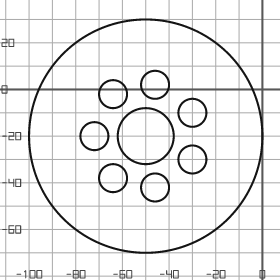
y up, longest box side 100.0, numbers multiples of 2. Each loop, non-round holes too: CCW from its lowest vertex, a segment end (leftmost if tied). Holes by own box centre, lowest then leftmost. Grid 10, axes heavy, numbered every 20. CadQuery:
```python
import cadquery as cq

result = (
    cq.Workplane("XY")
    .moveTo(-50.0, -20.0)
    .circle(50.0)
    .moveTo(-46.0, -42.0)
    .circle(6.0)
    .moveTo(-64.0, -38.0)
    .circle(6.0)
    .moveTo(-30.0, -30.0)
    .circle(6.0)
    .moveTo(-72.0, -20.0)
    .circle(6.0)
    .moveTo(-50.0, -20.0)
    .circle(12.0)
    .moveTo(-30.0, -10.0)
    .circle(6.0)
    .moveTo(-64.0, -2.0)
    .circle(6.0)
    .moveTo(-46.0, 2.0)
    .circle(6.0)
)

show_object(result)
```